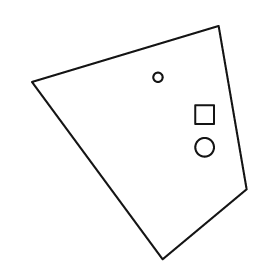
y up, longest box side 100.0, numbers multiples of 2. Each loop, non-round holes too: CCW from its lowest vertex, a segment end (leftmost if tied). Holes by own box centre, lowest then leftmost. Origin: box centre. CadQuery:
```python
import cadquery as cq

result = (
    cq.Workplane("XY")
    .moveTo(10.0, -50.0)
    .lineTo(46.0, -20.0)
    .lineTo(34.0, 50.0)
    .lineTo(-46.0, 26.0)
    .close()
    .moveTo(28.0, -2.0)
    .circle(4.0)
    .moveTo(24.0, 8.0)
    .lineTo(32.0, 8.0)
    .lineTo(32.0, 16.0)
    .lineTo(24.0, 16.0)
    .close()
    .moveTo(8.0, 28.0)
    .circle(2.0)
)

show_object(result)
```